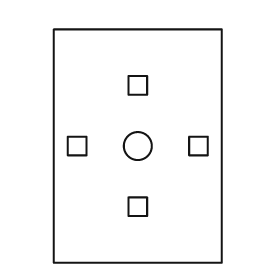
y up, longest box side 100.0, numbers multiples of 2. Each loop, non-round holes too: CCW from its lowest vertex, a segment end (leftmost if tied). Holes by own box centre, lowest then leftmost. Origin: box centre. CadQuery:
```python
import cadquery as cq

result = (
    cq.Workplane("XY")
    .moveTo(-36.0, -50.0)
    .lineTo(36.0, -50.0)
    .lineTo(36.0, 50.0)
    .lineTo(-36.0, 50.0)
    .close()
    .moveTo(-4.0, -30.0)
    .lineTo(4.0, -30.0)
    .lineTo(4.0, -22.0)
    .lineTo(-4.0, -22.0)
    .close()
    .moveTo(-30.0, -4.0)
    .lineTo(-22.0, -4.0)
    .lineTo(-22.0, 4.0)
    .lineTo(-30.0, 4.0)
    .close()
    .moveTo(0.0, 0.0)
    .circle(6.0)
    .moveTo(22.0, -4.0)
    .lineTo(30.0, -4.0)
    .lineTo(30.0, 4.0)
    .lineTo(22.0, 4.0)
    .close()
    .moveTo(-4.0, 22.0)
    .lineTo(4.0, 22.0)
    .lineTo(4.0, 30.0)
    .lineTo(-4.0, 30.0)
    .close()
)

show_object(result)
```